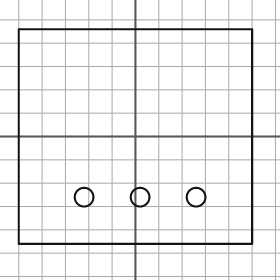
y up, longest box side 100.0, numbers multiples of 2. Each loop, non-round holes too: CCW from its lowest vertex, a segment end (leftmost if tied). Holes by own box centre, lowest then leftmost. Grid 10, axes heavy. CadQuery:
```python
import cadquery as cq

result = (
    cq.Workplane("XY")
    .moveTo(-50.0, -46.0)
    .lineTo(50.0, -46.0)
    .lineTo(50.0, 46.0)
    .lineTo(-50.0, 46.0)
    .close()
    .moveTo(-22.0, -26.0)
    .circle(4.0)
    .moveTo(2.0, -26.0)
    .circle(4.0)
    .moveTo(26.0, -26.0)
    .circle(4.0)
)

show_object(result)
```